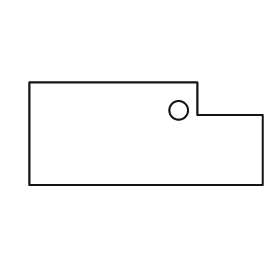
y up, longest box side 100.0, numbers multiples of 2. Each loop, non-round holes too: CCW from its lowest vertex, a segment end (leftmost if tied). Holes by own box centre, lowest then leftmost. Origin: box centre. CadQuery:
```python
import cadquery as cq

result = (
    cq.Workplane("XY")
    .moveTo(-50.0, -22.0)
    .lineTo(50.0, -22.0)
    .lineTo(50.0, 8.0)
    .lineTo(22.0, 8.0)
    .lineTo(22.0, 22.0)
    .lineTo(-50.0, 22.0)
    .close()
    .moveTo(14.0, 10.0)
    .circle(4.0)
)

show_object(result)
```